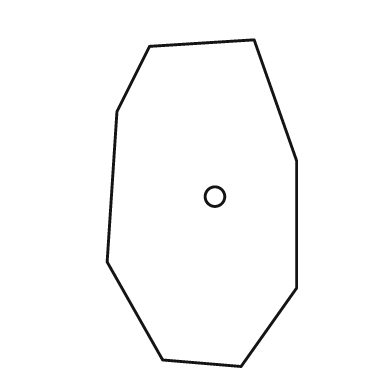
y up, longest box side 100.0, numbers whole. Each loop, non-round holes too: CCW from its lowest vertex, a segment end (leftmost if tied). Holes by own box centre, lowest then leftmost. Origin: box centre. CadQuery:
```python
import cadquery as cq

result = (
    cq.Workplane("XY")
    .moveTo(12.0, -50.0)
    .lineTo(29.0, -26.0)
    .lineTo(29.0, 13.0)
    .lineTo(16.0, 50.0)
    .lineTo(-16.0, 48.0)
    .lineTo(-26.0, 28.0)
    .lineTo(-29.0, -18.0)
    .lineTo(-12.0, -48.0)
    .close()
    .moveTo(4.0, 2.0)
    .circle(3.0)
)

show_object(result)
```